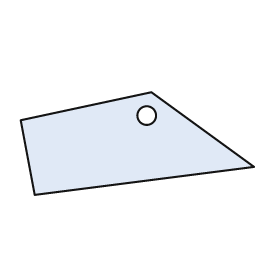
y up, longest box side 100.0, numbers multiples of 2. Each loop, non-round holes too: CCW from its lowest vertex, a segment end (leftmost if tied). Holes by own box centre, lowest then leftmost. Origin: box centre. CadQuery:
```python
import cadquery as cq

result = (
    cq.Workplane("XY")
    .moveTo(-44.0, -22.0)
    .lineTo(50.0, -10.0)
    .lineTo(6.0, 22.0)
    .lineTo(-50.0, 10.0)
    .close()
    .moveTo(4.0, 12.0)
    .circle(4.0)
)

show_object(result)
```